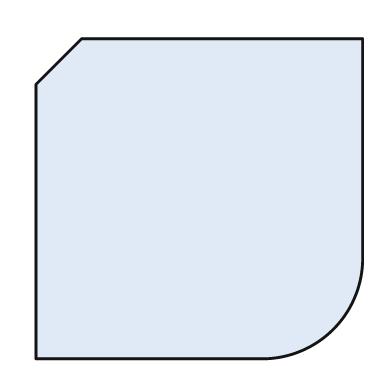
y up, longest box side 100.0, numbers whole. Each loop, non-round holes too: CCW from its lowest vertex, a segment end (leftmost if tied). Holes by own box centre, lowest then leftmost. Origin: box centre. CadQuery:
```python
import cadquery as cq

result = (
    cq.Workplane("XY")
    .moveTo(-50.0, -49.0)
    .lineTo(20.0, -49.0)
    .threePointArc((41.0, -40.0), (50.0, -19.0))
    .lineTo(50.0, 49.0)
    .lineTo(-36.0, 49.0)
    .lineTo(-50.0, 35.0)
    .close()
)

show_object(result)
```